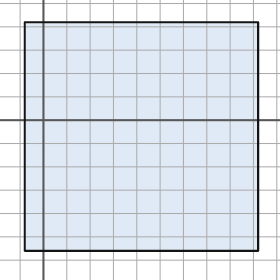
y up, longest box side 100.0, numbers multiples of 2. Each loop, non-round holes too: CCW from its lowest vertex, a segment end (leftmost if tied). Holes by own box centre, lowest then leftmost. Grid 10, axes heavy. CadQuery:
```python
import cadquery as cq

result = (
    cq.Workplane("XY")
    .moveTo(-8.0, -56.0)
    .lineTo(92.0, -56.0)
    .lineTo(92.0, 42.0)
    .lineTo(-8.0, 42.0)
    .close()
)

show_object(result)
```